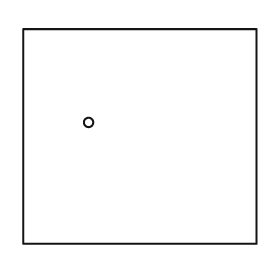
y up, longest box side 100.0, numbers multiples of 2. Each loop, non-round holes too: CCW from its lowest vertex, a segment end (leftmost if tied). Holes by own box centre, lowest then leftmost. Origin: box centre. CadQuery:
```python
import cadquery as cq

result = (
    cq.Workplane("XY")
    .moveTo(-50.0, -46.0)
    .lineTo(50.0, -46.0)
    .lineTo(50.0, 46.0)
    .lineTo(-50.0, 46.0)
    .close()
    .moveTo(-22.0, 6.0)
    .circle(2.0)
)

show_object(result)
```